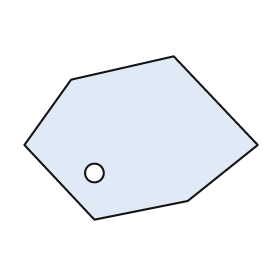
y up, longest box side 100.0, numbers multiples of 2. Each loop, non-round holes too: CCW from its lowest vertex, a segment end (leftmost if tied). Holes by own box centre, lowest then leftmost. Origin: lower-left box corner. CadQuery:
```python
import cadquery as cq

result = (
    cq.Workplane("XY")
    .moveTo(30.0, 0.0)
    .lineTo(70.0, 8.0)
    .lineTo(100.0, 32.0)
    .lineTo(64.0, 70.0)
    .lineTo(20.0, 60.0)
    .lineTo(0.0, 32.0)
    .close()
    .moveTo(30.0, 20.0)
    .circle(4.0)
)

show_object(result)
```